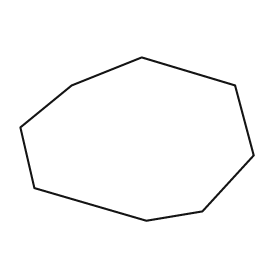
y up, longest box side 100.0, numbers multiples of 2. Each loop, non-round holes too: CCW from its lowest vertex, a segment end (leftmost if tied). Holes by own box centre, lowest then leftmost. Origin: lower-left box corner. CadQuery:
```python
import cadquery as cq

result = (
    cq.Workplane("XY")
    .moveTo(54.0, 0.0)
    .lineTo(78.0, 4.0)
    .lineTo(100.0, 28.0)
    .lineTo(92.0, 58.0)
    .lineTo(52.0, 70.0)
    .lineTo(22.0, 58.0)
    .lineTo(0.0, 40.0)
    .lineTo(6.0, 14.0)
    .close()
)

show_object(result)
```